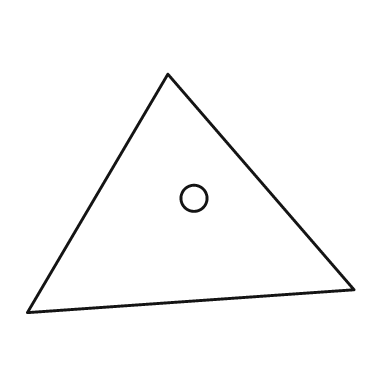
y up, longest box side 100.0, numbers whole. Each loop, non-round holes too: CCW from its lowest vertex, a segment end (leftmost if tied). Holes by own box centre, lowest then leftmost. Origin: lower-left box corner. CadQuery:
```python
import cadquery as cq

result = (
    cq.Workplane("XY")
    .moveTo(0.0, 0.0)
    .lineTo(100.0, 7.0)
    .lineTo(43.0, 73.0)
    .close()
    .moveTo(51.0, 35.0)
    .circle(4.0)
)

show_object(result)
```